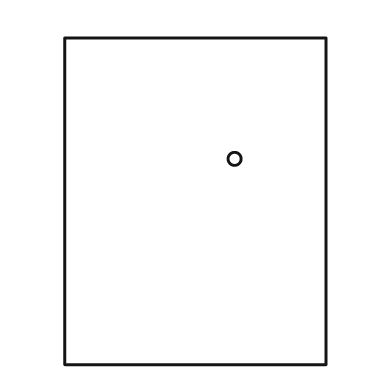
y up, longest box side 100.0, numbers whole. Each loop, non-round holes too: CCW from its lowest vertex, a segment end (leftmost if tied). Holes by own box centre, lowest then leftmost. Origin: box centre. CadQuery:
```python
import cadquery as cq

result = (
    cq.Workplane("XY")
    .moveTo(-40.0, -50.0)
    .lineTo(40.0, -50.0)
    .lineTo(40.0, 50.0)
    .lineTo(-40.0, 50.0)
    .close()
    .moveTo(12.0, 13.0)
    .circle(2.0)
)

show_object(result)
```